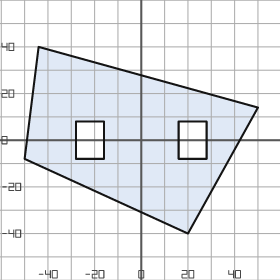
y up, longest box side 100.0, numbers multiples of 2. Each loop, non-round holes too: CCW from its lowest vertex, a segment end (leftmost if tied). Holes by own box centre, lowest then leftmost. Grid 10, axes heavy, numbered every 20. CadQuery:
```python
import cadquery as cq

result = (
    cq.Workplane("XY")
    .moveTo(20.0, -40.0)
    .lineTo(50.0, 14.0)
    .lineTo(-44.0, 40.0)
    .lineTo(-50.0, -8.0)
    .close()
    .moveTo(-28.0, -8.0)
    .lineTo(-16.0, -8.0)
    .lineTo(-16.0, 8.0)
    .lineTo(-28.0, 8.0)
    .close()
    .moveTo(16.0, -8.0)
    .lineTo(28.0, -8.0)
    .lineTo(28.0, 8.0)
    .lineTo(16.0, 8.0)
    .close()
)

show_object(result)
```